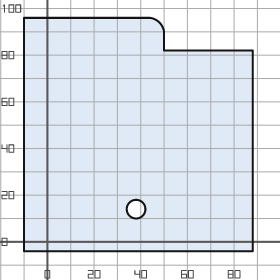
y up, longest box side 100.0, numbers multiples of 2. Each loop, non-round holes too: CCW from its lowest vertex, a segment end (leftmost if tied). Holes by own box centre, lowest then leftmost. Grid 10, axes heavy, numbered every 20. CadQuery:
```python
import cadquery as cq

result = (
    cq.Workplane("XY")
    .moveTo(-10.0, -4.0)
    .lineTo(88.0, -4.0)
    .lineTo(88.0, 82.0)
    .lineTo(50.0, 82.0)
    .lineTo(50.0, 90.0)
    .threePointArc((48.0, 94.0), (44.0, 96.0))
    .lineTo(-10.0, 96.0)
    .close()
    .moveTo(38.0, 14.0)
    .circle(4.0)
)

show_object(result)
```